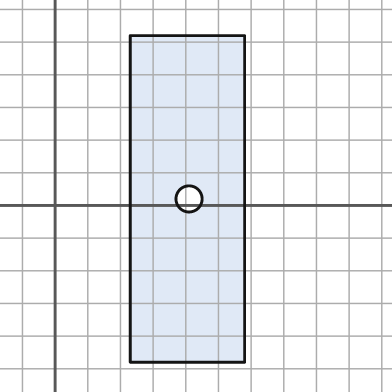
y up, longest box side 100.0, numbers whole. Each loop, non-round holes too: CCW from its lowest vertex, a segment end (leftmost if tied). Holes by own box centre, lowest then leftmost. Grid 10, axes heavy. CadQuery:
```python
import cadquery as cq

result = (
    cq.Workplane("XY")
    .moveTo(23.0, -48.0)
    .lineTo(58.0, -48.0)
    .lineTo(58.0, 52.0)
    .lineTo(23.0, 52.0)
    .close()
    .moveTo(41.0, 2.0)
    .circle(4.0)
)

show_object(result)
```